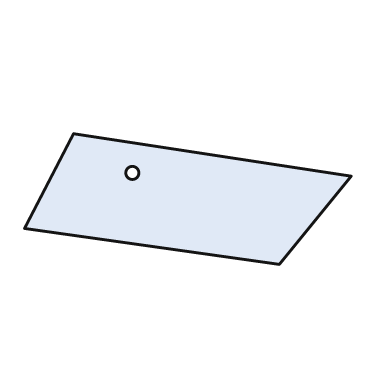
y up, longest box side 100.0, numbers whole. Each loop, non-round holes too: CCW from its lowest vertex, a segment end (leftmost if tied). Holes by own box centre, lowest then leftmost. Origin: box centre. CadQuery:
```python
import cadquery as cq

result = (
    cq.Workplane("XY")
    .moveTo(28.0, -20.0)
    .lineTo(50.0, 7.0)
    .lineTo(-35.0, 20.0)
    .lineTo(-50.0, -9.0)
    .close()
    .moveTo(-17.0, 8.0)
    .circle(2.0)
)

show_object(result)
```